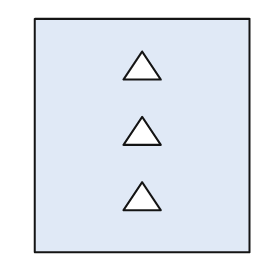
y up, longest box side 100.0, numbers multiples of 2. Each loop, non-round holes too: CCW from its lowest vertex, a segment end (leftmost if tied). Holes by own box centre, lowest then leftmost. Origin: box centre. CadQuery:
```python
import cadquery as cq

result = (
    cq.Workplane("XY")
    .moveTo(-46.0, -50.0)
    .lineTo(46.0, -50.0)
    .lineTo(46.0, 50.0)
    .lineTo(-46.0, 50.0)
    .close()
    .moveTo(-8.0, -32.0)
    .lineTo(8.0, -32.0)
    .lineTo(0.0, -20.0)
    .close()
    .moveTo(-8.0, -4.0)
    .lineTo(8.0, -4.0)
    .lineTo(0.0, 8.0)
    .close()
    .moveTo(-8.0, 24.0)
    .lineTo(8.0, 24.0)
    .lineTo(0.0, 36.0)
    .close()
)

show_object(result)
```